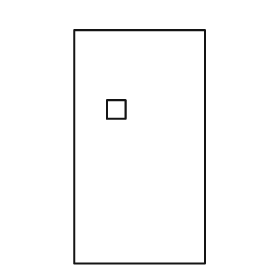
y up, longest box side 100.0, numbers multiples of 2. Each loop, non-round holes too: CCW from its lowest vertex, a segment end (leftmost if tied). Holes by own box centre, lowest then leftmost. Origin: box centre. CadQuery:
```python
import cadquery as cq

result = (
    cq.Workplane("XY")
    .moveTo(-28.0, -50.0)
    .lineTo(28.0, -50.0)
    .lineTo(28.0, 50.0)
    .lineTo(-28.0, 50.0)
    .close()
    .moveTo(-14.0, 12.0)
    .lineTo(-6.0, 12.0)
    .lineTo(-6.0, 20.0)
    .lineTo(-14.0, 20.0)
    .close()
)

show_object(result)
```